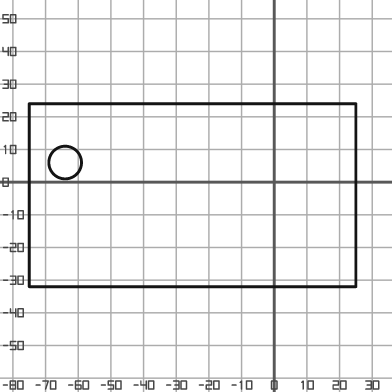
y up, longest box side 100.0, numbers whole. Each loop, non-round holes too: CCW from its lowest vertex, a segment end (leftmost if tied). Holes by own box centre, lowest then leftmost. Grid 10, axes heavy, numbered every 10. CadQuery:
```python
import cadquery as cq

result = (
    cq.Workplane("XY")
    .moveTo(-75.0, -32.0)
    .lineTo(25.0, -32.0)
    .lineTo(25.0, 24.0)
    .lineTo(-75.0, 24.0)
    .close()
    .moveTo(-64.0, 6.0)
    .circle(5.0)
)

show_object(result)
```